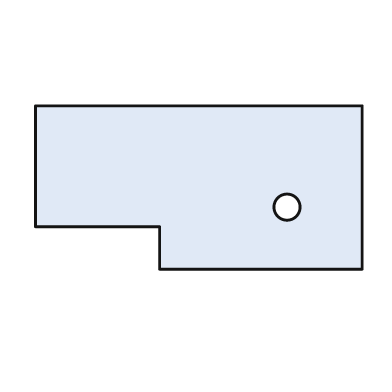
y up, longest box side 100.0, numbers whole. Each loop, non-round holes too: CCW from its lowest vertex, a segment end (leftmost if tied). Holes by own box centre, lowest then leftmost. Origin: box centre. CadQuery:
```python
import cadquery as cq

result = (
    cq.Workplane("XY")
    .moveTo(-12.0, -25.0)
    .lineTo(50.0, -25.0)
    .lineTo(50.0, 25.0)
    .lineTo(-50.0, 25.0)
    .lineTo(-50.0, -12.0)
    .lineTo(-12.0, -12.0)
    .close()
    .moveTo(27.0, -6.0)
    .circle(4.0)
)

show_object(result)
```